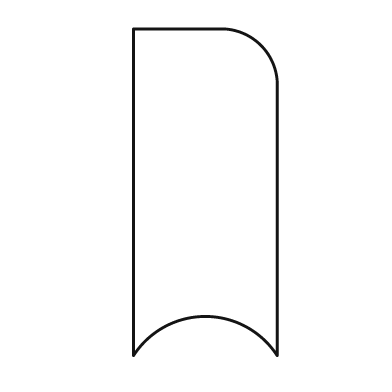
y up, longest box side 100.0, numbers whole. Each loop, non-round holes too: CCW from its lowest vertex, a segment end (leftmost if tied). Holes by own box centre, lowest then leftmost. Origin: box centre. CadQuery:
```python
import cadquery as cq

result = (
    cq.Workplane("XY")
    .moveTo(-22.0, -50.0)
    .threePointArc((0.0, -38.0), (22.0, -50.0))
    .lineTo(22.0, 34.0)
    .threePointArc((17.0, 45.0), (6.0, 50.0))
    .lineTo(-22.0, 50.0)
    .close()
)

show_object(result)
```